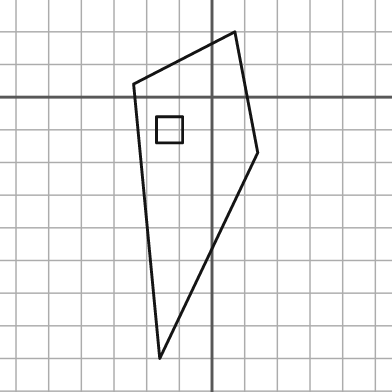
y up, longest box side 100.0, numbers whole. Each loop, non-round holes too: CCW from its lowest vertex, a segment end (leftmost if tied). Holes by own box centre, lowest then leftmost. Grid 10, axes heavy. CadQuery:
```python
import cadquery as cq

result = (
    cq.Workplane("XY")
    .moveTo(-16.0, -80.0)
    .lineTo(14.0, -17.0)
    .lineTo(7.0, 20.0)
    .lineTo(-24.0, 4.0)
    .close()
    .moveTo(-17.0, -14.0)
    .lineTo(-9.0, -14.0)
    .lineTo(-9.0, -6.0)
    .lineTo(-17.0, -6.0)
    .close()
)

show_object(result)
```